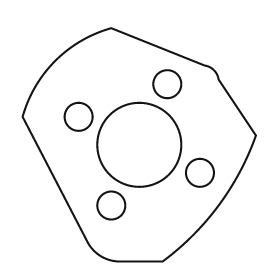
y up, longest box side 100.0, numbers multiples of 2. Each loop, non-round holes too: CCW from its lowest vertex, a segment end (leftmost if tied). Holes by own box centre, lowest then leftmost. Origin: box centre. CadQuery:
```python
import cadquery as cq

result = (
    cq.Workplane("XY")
    .moveTo(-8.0, -50.0)
    .lineTo(10.0, -50.0)
    .threePointArc((34.0, -26.0), (50.0, 4.0))
    .lineTo(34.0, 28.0)
    .threePointArc((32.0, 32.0), (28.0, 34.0))
    .lineTo(-12.0, 50.0)
    .threePointArc((-36.0, 36.0), (-50.0, 12.0))
    .lineTo(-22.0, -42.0)
    .threePointArc((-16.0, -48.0), (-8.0, -50.0))
    .close()
    .moveTo(-12.0, -26.0)
    .circle(6.0)
    .moveTo(26.0, -12.0)
    .circle(6.0)
    .moveTo(0.0, 0.0)
    .circle(18.0)
    .moveTo(-26.0, 12.0)
    .circle(6.0)
    .moveTo(12.0, 26.0)
    .circle(6.0)
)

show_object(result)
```